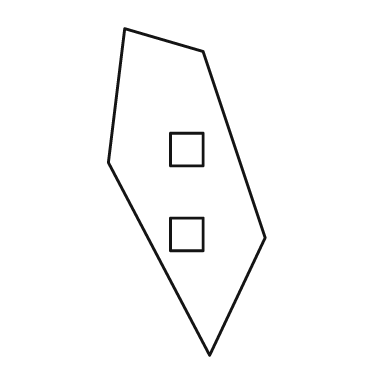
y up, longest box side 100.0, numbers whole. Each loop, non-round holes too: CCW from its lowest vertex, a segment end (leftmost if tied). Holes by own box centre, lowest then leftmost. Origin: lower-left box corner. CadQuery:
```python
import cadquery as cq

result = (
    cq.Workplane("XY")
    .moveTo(31.0, 0.0)
    .lineTo(48.0, 36.0)
    .lineTo(29.0, 93.0)
    .lineTo(5.0, 100.0)
    .lineTo(0.0, 59.0)
    .close()
    .moveTo(19.0, 32.0)
    .lineTo(29.0, 32.0)
    .lineTo(29.0, 42.0)
    .lineTo(19.0, 42.0)
    .close()
    .moveTo(19.0, 58.0)
    .lineTo(29.0, 58.0)
    .lineTo(29.0, 68.0)
    .lineTo(19.0, 68.0)
    .close()
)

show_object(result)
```